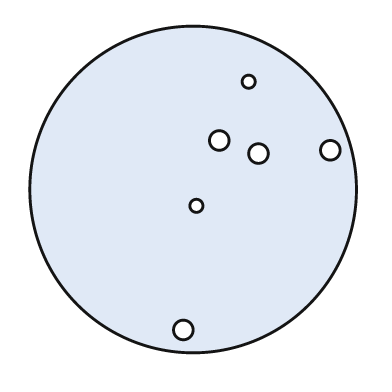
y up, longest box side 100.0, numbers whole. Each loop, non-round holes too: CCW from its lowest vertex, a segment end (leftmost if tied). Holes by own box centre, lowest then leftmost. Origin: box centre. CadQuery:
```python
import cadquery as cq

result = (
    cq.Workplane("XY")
    .moveTo(0.0, 0.0)
    .circle(50.0)
    .moveTo(-3.0, -43.0)
    .circle(3.0)
    .moveTo(1.0, -5.0)
    .circle(2.0)
    .moveTo(20.0, 11.0)
    .circle(3.0)
    .moveTo(42.0, 12.0)
    .circle(3.0)
    .moveTo(8.0, 15.0)
    .circle(3.0)
    .moveTo(17.0, 33.0)
    .circle(2.0)
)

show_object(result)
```